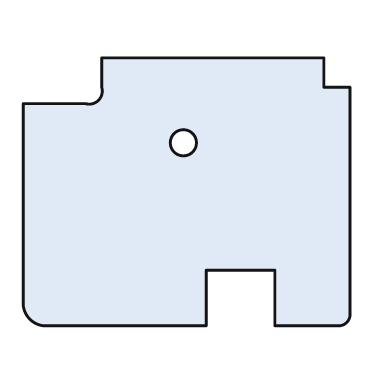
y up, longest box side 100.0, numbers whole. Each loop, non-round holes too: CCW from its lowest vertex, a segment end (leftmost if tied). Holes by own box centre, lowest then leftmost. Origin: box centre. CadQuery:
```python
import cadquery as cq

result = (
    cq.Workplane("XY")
    .moveTo(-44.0, -41.0)
    .lineTo(6.0, -41.0)
    .lineTo(6.0, -24.0)
    .lineTo(27.0, -24.0)
    .lineTo(27.0, -41.0)
    .lineTo(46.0, -41.0)
    .threePointArc((49.0, -40.0), (50.0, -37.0))
    .lineTo(50.0, 32.0)
    .lineTo(42.0, 32.0)
    .lineTo(42.0, 41.0)
    .lineTo(-26.0, 41.0)
    .lineTo(-26.0, 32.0)
    .threePointArc((-27.0, 28.0), (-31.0, 27.0))
    .lineTo(-50.0, 27.0)
    .lineTo(-50.0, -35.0)
    .threePointArc((-48.0, -39.0), (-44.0, -41.0))
    .close()
    .moveTo(-1.0, 15.0)
    .circle(4.0)
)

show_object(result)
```